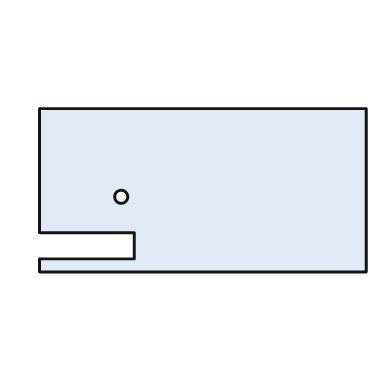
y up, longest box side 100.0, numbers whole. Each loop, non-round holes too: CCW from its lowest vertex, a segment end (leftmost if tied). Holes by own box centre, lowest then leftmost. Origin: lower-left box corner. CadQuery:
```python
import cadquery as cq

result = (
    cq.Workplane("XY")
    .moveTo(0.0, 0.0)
    .lineTo(100.0, 0.0)
    .lineTo(100.0, 50.0)
    .lineTo(0.0, 50.0)
    .lineTo(0.0, 12.0)
    .lineTo(29.0, 12.0)
    .lineTo(29.0, 4.0)
    .lineTo(0.0, 4.0)
    .close()
    .moveTo(25.0, 23.0)
    .circle(2.0)
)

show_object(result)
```